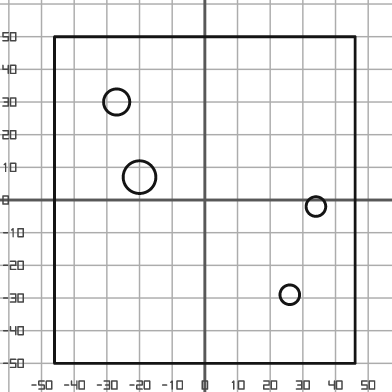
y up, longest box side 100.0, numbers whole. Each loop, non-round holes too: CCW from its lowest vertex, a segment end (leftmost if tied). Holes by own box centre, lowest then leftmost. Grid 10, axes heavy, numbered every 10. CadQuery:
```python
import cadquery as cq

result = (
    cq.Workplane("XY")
    .moveTo(-46.0, -50.0)
    .lineTo(46.0, -50.0)
    .lineTo(46.0, 50.0)
    .lineTo(-46.0, 50.0)
    .close()
    .moveTo(26.0, -29.0)
    .circle(3.0)
    .moveTo(34.0, -2.0)
    .circle(3.0)
    .moveTo(-20.0, 7.0)
    .circle(5.0)
    .moveTo(-27.0, 30.0)
    .circle(4.0)
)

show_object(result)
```